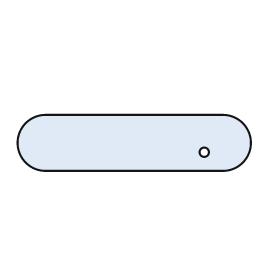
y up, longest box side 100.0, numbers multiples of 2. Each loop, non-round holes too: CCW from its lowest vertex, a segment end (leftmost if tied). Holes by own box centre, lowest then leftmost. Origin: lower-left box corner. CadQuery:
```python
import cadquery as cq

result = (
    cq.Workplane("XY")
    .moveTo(12.0, 0.0)
    .lineTo(88.0, 0.0)
    .threePointArc((100.0, 12.0), (88.0, 24.0))
    .lineTo(12.0, 24.0)
    .threePointArc((0.0, 12.0), (12.0, 0.0))
    .close()
    .moveTo(80.0, 8.0)
    .circle(2.0)
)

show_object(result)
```